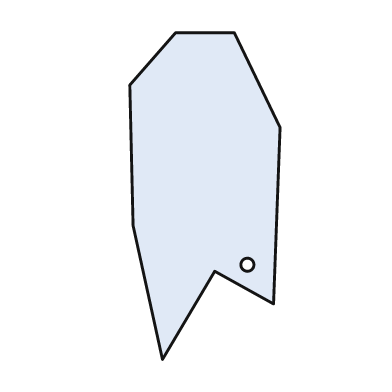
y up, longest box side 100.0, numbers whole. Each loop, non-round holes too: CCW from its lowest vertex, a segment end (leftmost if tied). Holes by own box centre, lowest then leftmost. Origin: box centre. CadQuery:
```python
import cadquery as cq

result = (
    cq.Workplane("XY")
    .moveTo(-13.0, -50.0)
    .lineTo(3.0, -23.0)
    .lineTo(21.0, -33.0)
    .lineTo(23.0, 21.0)
    .lineTo(9.0, 50.0)
    .lineTo(-9.0, 50.0)
    .lineTo(-23.0, 34.0)
    .lineTo(-22.0, -9.0)
    .close()
    .moveTo(13.0, -21.0)
    .circle(2.0)
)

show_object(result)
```